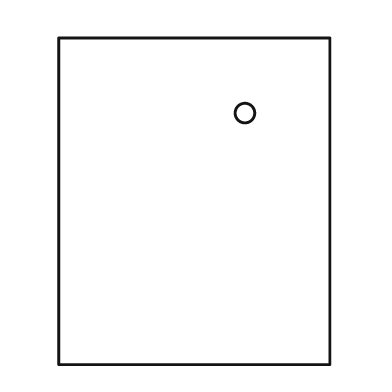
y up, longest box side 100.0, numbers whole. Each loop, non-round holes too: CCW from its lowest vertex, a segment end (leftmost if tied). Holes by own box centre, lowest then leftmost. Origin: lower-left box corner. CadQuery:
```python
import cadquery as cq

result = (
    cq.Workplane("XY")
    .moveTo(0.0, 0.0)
    .lineTo(83.0, 0.0)
    .lineTo(83.0, 100.0)
    .lineTo(0.0, 100.0)
    .close()
    .moveTo(57.0, 77.0)
    .circle(3.0)
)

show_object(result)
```